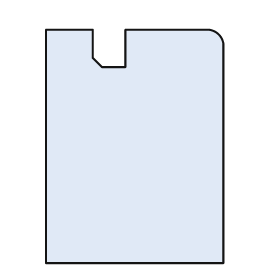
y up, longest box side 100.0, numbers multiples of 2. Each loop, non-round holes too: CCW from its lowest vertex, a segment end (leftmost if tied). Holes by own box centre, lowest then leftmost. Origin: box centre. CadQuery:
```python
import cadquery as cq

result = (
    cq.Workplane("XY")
    .moveTo(-38.0, -50.0)
    .lineTo(38.0, -50.0)
    .lineTo(38.0, 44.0)
    .threePointArc((36.0, 48.0), (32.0, 50.0))
    .lineTo(-4.0, 50.0)
    .lineTo(-4.0, 34.0)
    .lineTo(-14.0, 34.0)
    .lineTo(-18.0, 38.0)
    .lineTo(-18.0, 50.0)
    .lineTo(-38.0, 50.0)
    .close()
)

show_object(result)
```